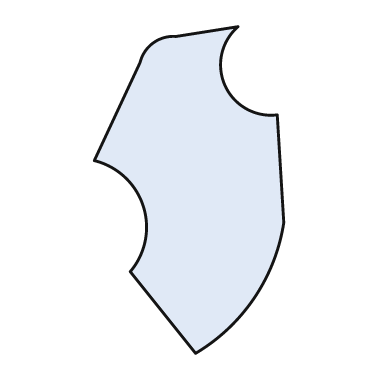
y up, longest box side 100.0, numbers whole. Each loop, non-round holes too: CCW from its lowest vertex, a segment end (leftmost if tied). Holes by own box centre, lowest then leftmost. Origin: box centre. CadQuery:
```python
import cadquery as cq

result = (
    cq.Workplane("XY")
    .moveTo(2.0, -50.0)
    .threePointArc((20.0, -33.0), (29.0, -10.0))
    .lineTo(27.0, 23.0)
    .threePointArc((11.0, 32.0), (15.0, 50.0))
    .lineTo(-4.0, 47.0)
    .threePointArc((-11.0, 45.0), (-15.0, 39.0))
    .lineTo(-29.0, 9.0)
    .threePointArc((-14.0, -5.0), (-18.0, -25.0))
    .close()
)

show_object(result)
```